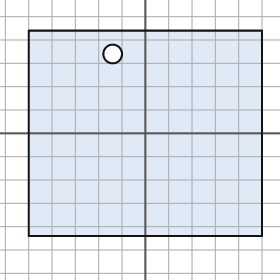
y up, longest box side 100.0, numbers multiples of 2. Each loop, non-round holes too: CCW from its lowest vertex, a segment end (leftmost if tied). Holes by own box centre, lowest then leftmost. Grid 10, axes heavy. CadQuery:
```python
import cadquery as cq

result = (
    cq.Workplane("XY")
    .moveTo(-50.0, -44.0)
    .lineTo(50.0, -44.0)
    .lineTo(50.0, 44.0)
    .lineTo(-50.0, 44.0)
    .close()
    .moveTo(-14.0, 34.0)
    .circle(4.0)
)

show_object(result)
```